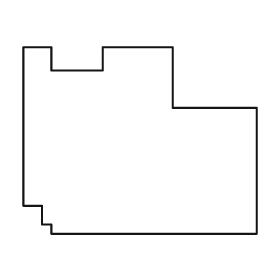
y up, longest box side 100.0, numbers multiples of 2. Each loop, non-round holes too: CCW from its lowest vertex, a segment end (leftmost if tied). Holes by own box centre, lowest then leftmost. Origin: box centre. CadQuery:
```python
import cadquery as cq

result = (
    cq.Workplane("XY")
    .moveTo(-38.0, -40.0)
    .lineTo(50.0, -40.0)
    .lineTo(50.0, 14.0)
    .lineTo(14.0, 14.0)
    .lineTo(14.0, 40.0)
    .lineTo(-16.0, 40.0)
    .lineTo(-16.0, 30.0)
    .lineTo(-38.0, 30.0)
    .lineTo(-38.0, 40.0)
    .lineTo(-50.0, 40.0)
    .lineTo(-50.0, -28.0)
    .lineTo(-42.0, -28.0)
    .lineTo(-42.0, -36.0)
    .lineTo(-38.0, -36.0)
    .close()
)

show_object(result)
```